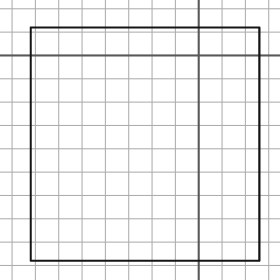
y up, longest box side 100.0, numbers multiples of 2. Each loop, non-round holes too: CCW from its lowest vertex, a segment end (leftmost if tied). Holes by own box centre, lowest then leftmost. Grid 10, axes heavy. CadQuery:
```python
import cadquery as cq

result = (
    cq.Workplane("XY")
    .moveTo(-72.0, -88.0)
    .lineTo(26.0, -88.0)
    .lineTo(26.0, 12.0)
    .lineTo(-72.0, 12.0)
    .close()
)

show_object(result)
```